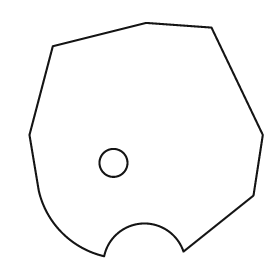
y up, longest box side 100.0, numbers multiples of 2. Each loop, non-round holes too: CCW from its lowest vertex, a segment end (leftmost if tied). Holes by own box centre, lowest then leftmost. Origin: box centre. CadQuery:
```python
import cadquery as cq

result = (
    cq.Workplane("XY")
    .moveTo(-18.0, -50.0)
    .threePointArc((-2.0, -36.0), (16.0, -48.0))
    .lineTo(46.0, -24.0)
    .lineTo(50.0, 2.0)
    .lineTo(28.0, 48.0)
    .lineTo(0.0, 50.0)
    .lineTo(-40.0, 40.0)
    .lineTo(-50.0, 2.0)
    .lineTo(-46.0, -22.0)
    .threePointArc((-36.0, -40.0), (-18.0, -50.0))
    .close()
    .moveTo(-14.0, -10.0)
    .circle(6.0)
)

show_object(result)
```